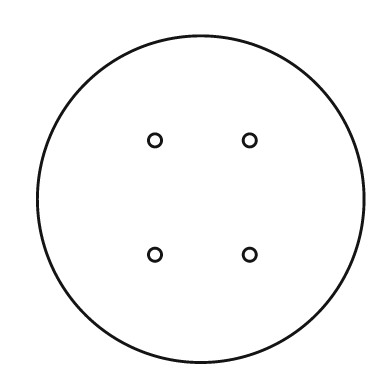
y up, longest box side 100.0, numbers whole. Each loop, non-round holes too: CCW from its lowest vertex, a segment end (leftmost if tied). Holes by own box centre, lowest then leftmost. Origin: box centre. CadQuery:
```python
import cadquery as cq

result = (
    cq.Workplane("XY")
    .moveTo(0.0, 0.0)
    .circle(50.0)
    .moveTo(-14.0, -17.0)
    .circle(2.0)
    .moveTo(15.0, -17.0)
    .circle(2.0)
    .moveTo(-14.0, 18.0)
    .circle(2.0)
    .moveTo(15.0, 18.0)
    .circle(2.0)
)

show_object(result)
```